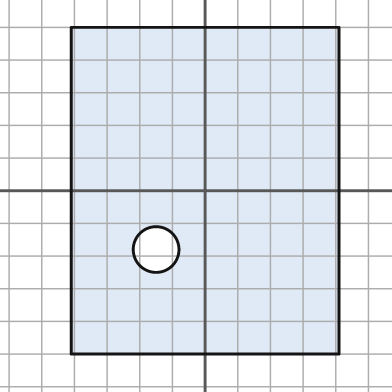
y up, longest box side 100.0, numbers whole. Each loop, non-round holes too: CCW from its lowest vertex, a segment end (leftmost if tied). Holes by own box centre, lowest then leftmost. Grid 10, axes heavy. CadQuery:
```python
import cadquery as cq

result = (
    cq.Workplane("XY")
    .moveTo(-41.0, -50.0)
    .lineTo(41.0, -50.0)
    .lineTo(41.0, 50.0)
    .lineTo(-41.0, 50.0)
    .close()
    .moveTo(-15.0, -18.0)
    .circle(7.0)
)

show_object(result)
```